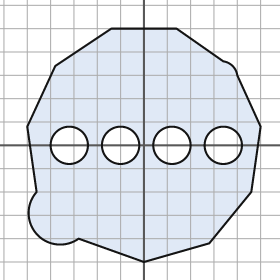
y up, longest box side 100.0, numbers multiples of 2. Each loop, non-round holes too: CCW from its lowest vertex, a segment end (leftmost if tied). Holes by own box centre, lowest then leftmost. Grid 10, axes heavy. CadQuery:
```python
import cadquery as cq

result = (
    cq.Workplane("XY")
    .moveTo(0.0, -50.0)
    .lineTo(28.0, -42.0)
    .lineTo(46.0, -20.0)
    .lineTo(50.0, 8.0)
    .lineTo(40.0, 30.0)
    .threePointArc((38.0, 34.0), (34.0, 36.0))
    .lineTo(14.0, 50.0)
    .lineTo(-14.0, 50.0)
    .lineTo(-38.0, 34.0)
    .lineTo(-50.0, 8.0)
    .lineTo(-46.0, -20.0)
    .threePointArc((-46.0, -38.0), (-28.0, -40.0))
    .close()
    .moveTo(-32.0, 0.0)
    .circle(8.0)
    .moveTo(-10.0, 0.0)
    .circle(8.0)
    .moveTo(12.0, 0.0)
    .circle(8.0)
    .moveTo(34.0, 0.0)
    .circle(8.0)
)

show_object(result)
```